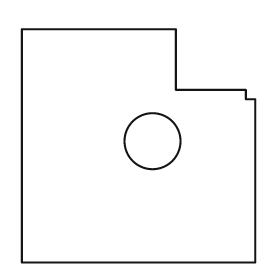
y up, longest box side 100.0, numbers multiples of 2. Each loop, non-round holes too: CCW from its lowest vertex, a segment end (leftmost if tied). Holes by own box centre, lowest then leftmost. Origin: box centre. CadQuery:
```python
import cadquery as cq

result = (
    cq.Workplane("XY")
    .moveTo(-50.0, -50.0)
    .lineTo(50.0, -50.0)
    .lineTo(50.0, 20.0)
    .lineTo(46.0, 20.0)
    .lineTo(46.0, 24.0)
    .lineTo(16.0, 24.0)
    .lineTo(16.0, 50.0)
    .lineTo(-50.0, 50.0)
    .close()
    .moveTo(6.0, 2.0)
    .circle(12.0)
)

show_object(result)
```